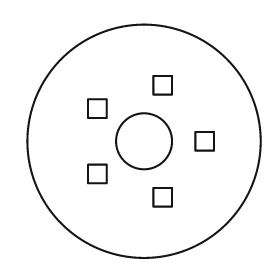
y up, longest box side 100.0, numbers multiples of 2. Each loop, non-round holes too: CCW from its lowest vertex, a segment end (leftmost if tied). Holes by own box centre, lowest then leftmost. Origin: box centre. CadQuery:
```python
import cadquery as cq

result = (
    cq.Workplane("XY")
    .moveTo(0.0, 0.0)
    .circle(50.0)
    .moveTo(4.0, -28.0)
    .lineTo(12.0, -28.0)
    .lineTo(12.0, -20.0)
    .lineTo(4.0, -20.0)
    .close()
    .moveTo(-24.0, -18.0)
    .lineTo(-16.0, -18.0)
    .lineTo(-16.0, -10.0)
    .lineTo(-24.0, -10.0)
    .close()
    .moveTo(0.0, 0.0)
    .circle(12.0)
    .moveTo(22.0, -4.0)
    .lineTo(30.0, -4.0)
    .lineTo(30.0, 4.0)
    .lineTo(22.0, 4.0)
    .close()
    .moveTo(-24.0, 10.0)
    .lineTo(-16.0, 10.0)
    .lineTo(-16.0, 18.0)
    .lineTo(-24.0, 18.0)
    .close()
    .moveTo(4.0, 20.0)
    .lineTo(12.0, 20.0)
    .lineTo(12.0, 28.0)
    .lineTo(4.0, 28.0)
    .close()
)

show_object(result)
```